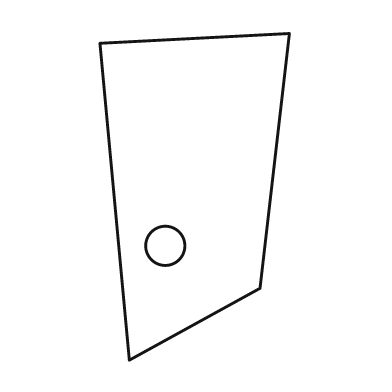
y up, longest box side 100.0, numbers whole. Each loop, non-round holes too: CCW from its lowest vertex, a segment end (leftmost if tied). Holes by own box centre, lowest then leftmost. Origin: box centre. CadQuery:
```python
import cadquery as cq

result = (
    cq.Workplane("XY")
    .moveTo(-20.0, -50.0)
    .lineTo(20.0, -28.0)
    .lineTo(29.0, 50.0)
    .lineTo(-29.0, 47.0)
    .close()
    .moveTo(-9.0, -15.0)
    .circle(6.0)
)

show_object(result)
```